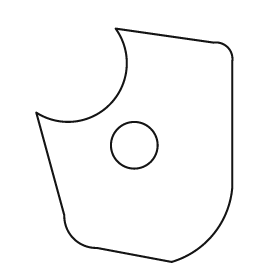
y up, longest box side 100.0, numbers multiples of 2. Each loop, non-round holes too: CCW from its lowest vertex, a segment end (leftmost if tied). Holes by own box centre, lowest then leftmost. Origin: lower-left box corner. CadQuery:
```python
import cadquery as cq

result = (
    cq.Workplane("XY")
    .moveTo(58.0, 0.0)
    .threePointArc((76.0, 12.0), (84.0, 32.0))
    .lineTo(84.0, 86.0)
    .threePointArc((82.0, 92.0), (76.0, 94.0))
    .lineTo(34.0, 100.0)
    .threePointArc((32.0, 68.0), (0.0, 64.0))
    .lineTo(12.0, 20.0)
    .threePointArc((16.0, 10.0), (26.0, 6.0))
    .close()
    .moveTo(42.0, 50.0)
    .circle(10.0)
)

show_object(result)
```